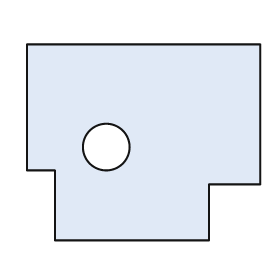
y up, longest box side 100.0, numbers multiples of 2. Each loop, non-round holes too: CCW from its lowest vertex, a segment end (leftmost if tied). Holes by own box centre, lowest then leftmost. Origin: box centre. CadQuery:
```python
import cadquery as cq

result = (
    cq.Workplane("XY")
    .moveTo(-38.0, -42.0)
    .lineTo(28.0, -42.0)
    .lineTo(28.0, -18.0)
    .lineTo(50.0, -18.0)
    .lineTo(50.0, 42.0)
    .lineTo(-50.0, 42.0)
    .lineTo(-50.0, -12.0)
    .lineTo(-38.0, -12.0)
    .close()
    .moveTo(-16.0, -2.0)
    .circle(10.0)
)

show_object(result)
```